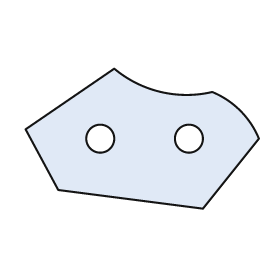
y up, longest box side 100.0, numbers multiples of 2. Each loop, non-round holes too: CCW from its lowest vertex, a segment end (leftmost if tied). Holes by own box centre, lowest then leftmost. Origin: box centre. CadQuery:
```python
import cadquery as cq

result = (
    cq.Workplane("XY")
    .moveTo(26.0, -30.0)
    .lineTo(50.0, 0.0)
    .threePointArc((42.0, 12.0), (30.0, 20.0))
    .threePointArc((8.0, 20.0), (-12.0, 30.0))
    .lineTo(-50.0, 4.0)
    .lineTo(-36.0, -22.0)
    .close()
    .moveTo(-18.0, 0.0)
    .circle(6.0)
    .moveTo(20.0, 0.0)
    .circle(6.0)
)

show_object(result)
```